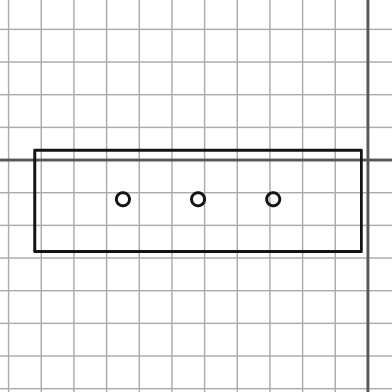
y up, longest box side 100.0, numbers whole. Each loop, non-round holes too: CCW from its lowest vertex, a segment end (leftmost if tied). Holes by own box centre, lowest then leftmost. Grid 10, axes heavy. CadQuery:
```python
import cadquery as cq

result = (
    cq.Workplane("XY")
    .moveTo(-102.0, -28.0)
    .lineTo(-2.0, -28.0)
    .lineTo(-2.0, 3.0)
    .lineTo(-102.0, 3.0)
    .close()
    .moveTo(-75.0, -12.0)
    .circle(2.0)
    .moveTo(-52.0, -12.0)
    .circle(2.0)
    .moveTo(-29.0, -12.0)
    .circle(2.0)
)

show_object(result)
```